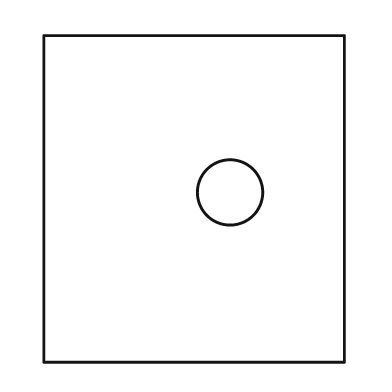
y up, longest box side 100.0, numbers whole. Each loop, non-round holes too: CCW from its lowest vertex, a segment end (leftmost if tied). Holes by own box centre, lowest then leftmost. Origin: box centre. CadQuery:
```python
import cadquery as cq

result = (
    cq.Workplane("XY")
    .moveTo(-46.0, -50.0)
    .lineTo(46.0, -50.0)
    .lineTo(46.0, 50.0)
    .lineTo(-46.0, 50.0)
    .close()
    .moveTo(11.0, 2.0)
    .circle(10.0)
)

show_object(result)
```